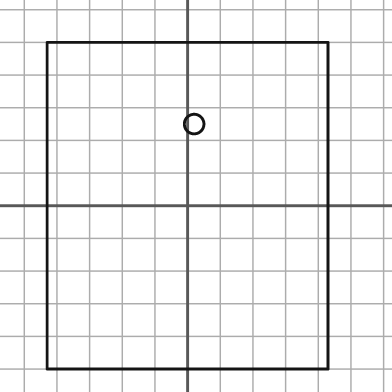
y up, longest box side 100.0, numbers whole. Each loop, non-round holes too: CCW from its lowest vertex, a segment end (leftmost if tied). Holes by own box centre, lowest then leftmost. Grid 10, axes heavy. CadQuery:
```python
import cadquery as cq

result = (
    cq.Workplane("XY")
    .moveTo(-43.0, -50.0)
    .lineTo(43.0, -50.0)
    .lineTo(43.0, 50.0)
    .lineTo(-43.0, 50.0)
    .close()
    .moveTo(2.0, 25.0)
    .circle(3.0)
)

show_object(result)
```